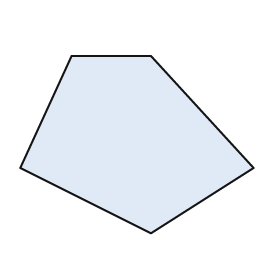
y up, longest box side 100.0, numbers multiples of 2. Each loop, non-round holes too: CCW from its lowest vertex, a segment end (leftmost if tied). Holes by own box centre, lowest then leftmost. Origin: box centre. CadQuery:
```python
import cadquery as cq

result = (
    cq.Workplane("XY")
    .moveTo(6.0, -38.0)
    .lineTo(50.0, -10.0)
    .lineTo(6.0, 38.0)
    .lineTo(-28.0, 38.0)
    .lineTo(-50.0, -10.0)
    .close()
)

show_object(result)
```